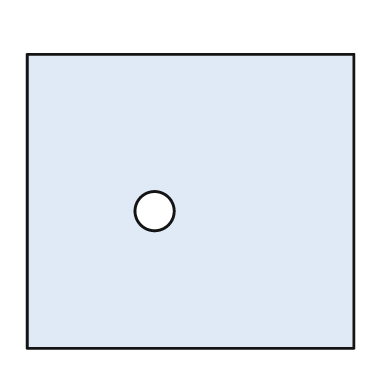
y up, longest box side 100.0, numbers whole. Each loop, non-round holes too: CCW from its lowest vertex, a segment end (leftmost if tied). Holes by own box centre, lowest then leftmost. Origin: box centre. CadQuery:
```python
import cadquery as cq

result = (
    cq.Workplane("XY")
    .moveTo(-50.0, -45.0)
    .lineTo(50.0, -45.0)
    .lineTo(50.0, 45.0)
    .lineTo(-50.0, 45.0)
    .close()
    .moveTo(-11.0, -3.0)
    .circle(6.0)
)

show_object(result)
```